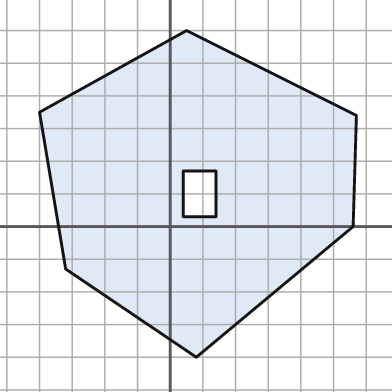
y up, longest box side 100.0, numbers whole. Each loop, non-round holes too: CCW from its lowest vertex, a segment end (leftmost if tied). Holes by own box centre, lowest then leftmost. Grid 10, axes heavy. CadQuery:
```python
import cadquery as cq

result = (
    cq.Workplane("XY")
    .moveTo(8.0, -40.0)
    .lineTo(56.0, 0.0)
    .lineTo(57.0, 34.0)
    .lineTo(5.0, 60.0)
    .lineTo(-40.0, 35.0)
    .lineTo(-32.0, -13.0)
    .close()
    .moveTo(4.0, 3.0)
    .lineTo(14.0, 3.0)
    .lineTo(14.0, 17.0)
    .lineTo(4.0, 17.0)
    .close()
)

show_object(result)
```